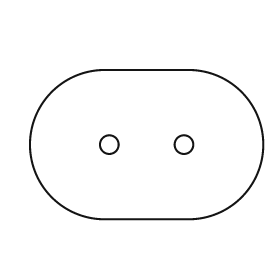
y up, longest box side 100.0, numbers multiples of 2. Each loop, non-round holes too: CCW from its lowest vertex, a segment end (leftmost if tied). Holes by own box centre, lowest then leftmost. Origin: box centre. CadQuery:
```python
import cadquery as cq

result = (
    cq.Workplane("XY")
    .moveTo(-18.0, -32.0)
    .lineTo(18.0, -32.0)
    .threePointArc((50.0, 0.0), (18.0, 32.0))
    .lineTo(-18.0, 32.0)
    .threePointArc((-50.0, 0.0), (-18.0, -32.0))
    .close()
    .moveTo(-16.0, 0.0)
    .circle(4.0)
    .moveTo(16.0, 0.0)
    .circle(4.0)
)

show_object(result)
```